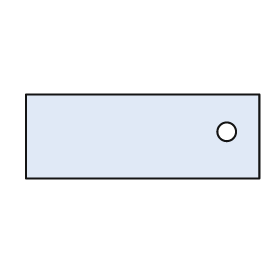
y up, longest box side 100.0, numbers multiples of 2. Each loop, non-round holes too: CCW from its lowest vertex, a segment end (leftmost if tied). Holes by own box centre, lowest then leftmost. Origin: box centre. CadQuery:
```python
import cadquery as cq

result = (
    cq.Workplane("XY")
    .moveTo(-50.0, -18.0)
    .lineTo(50.0, -18.0)
    .lineTo(50.0, 18.0)
    .lineTo(-50.0, 18.0)
    .close()
    .moveTo(36.0, 2.0)
    .circle(4.0)
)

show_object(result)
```